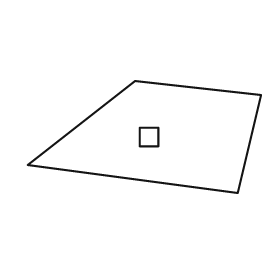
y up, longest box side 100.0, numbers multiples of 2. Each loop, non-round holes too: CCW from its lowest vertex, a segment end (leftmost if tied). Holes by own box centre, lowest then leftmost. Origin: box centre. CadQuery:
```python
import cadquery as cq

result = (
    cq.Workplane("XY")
    .moveTo(40.0, -24.0)
    .lineTo(50.0, 18.0)
    .lineTo(-4.0, 24.0)
    .lineTo(-50.0, -12.0)
    .close()
    .moveTo(-2.0, -4.0)
    .lineTo(6.0, -4.0)
    .lineTo(6.0, 4.0)
    .lineTo(-2.0, 4.0)
    .close()
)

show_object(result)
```